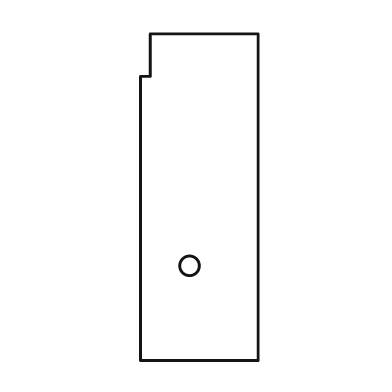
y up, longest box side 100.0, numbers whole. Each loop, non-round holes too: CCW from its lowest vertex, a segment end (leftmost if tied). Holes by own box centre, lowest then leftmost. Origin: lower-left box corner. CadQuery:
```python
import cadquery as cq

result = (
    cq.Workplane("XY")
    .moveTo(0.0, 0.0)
    .lineTo(36.0, 0.0)
    .lineTo(36.0, 100.0)
    .lineTo(3.0, 100.0)
    .lineTo(3.0, 87.0)
    .lineTo(0.0, 87.0)
    .close()
    .moveTo(15.0, 29.0)
    .circle(3.0)
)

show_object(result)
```